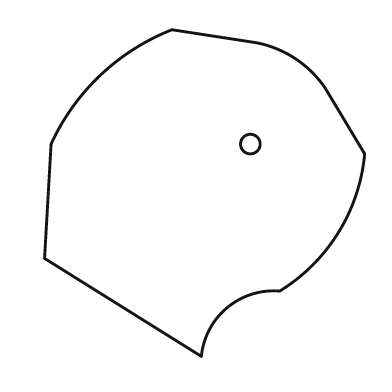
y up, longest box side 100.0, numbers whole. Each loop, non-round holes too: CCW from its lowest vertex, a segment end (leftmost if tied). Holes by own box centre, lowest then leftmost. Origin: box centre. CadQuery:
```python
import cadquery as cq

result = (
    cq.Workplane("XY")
    .moveTo(-1.0, -50.0)
    .threePointArc((7.0, -35.0), (23.0, -30.0))
    .threePointArc((41.0, -12.0), (49.0, 12.0))
    .lineTo(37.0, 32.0)
    .threePointArc((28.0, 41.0), (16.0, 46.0))
    .lineTo(-10.0, 50.0)
    .threePointArc((-32.0, 36.0), (-47.0, 15.0))
    .lineTo(-49.0, -20.0)
    .close()
    .moveTo(14.0, 15.0)
    .circle(3.0)
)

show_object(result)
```